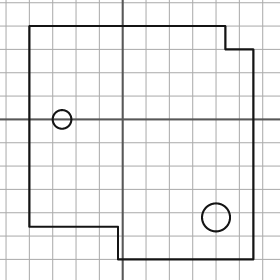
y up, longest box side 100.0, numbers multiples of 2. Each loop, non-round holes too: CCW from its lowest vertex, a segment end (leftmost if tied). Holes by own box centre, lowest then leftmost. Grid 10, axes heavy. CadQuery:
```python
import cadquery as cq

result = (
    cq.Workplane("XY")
    .moveTo(-2.0, -60.0)
    .lineTo(56.0, -60.0)
    .lineTo(56.0, 30.0)
    .lineTo(44.0, 30.0)
    .lineTo(44.0, 40.0)
    .lineTo(-40.0, 40.0)
    .lineTo(-40.0, -46.0)
    .lineTo(-2.0, -46.0)
    .close()
    .moveTo(40.0, -42.0)
    .circle(6.0)
    .moveTo(-26.0, 0.0)
    .circle(4.0)
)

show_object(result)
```